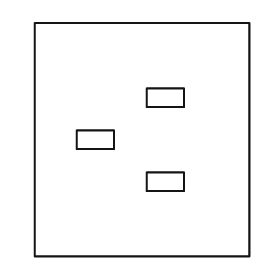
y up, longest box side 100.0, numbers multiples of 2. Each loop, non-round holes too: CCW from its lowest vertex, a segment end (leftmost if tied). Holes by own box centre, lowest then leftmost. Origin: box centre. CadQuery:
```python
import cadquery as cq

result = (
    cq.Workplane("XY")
    .moveTo(-46.0, -50.0)
    .lineTo(46.0, -50.0)
    .lineTo(46.0, 50.0)
    .lineTo(-46.0, 50.0)
    .close()
    .moveTo(2.0, -22.0)
    .lineTo(18.0, -22.0)
    .lineTo(18.0, -14.0)
    .lineTo(2.0, -14.0)
    .close()
    .moveTo(-28.0, -4.0)
    .lineTo(-12.0, -4.0)
    .lineTo(-12.0, 4.0)
    .lineTo(-28.0, 4.0)
    .close()
    .moveTo(2.0, 14.0)
    .lineTo(18.0, 14.0)
    .lineTo(18.0, 22.0)
    .lineTo(2.0, 22.0)
    .close()
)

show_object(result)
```